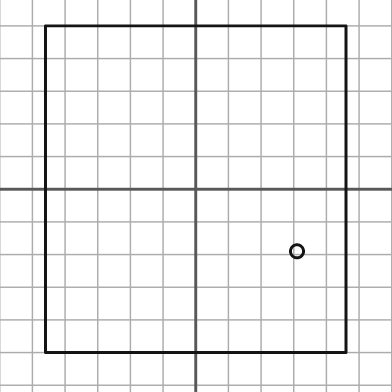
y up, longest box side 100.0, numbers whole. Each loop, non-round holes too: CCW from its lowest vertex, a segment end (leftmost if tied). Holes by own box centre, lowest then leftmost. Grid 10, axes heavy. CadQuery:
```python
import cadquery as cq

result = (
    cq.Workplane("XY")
    .moveTo(-46.0, -50.0)
    .lineTo(46.0, -50.0)
    .lineTo(46.0, 50.0)
    .lineTo(-46.0, 50.0)
    .close()
    .moveTo(31.0, -19.0)
    .circle(2.0)
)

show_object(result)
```